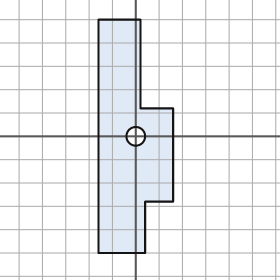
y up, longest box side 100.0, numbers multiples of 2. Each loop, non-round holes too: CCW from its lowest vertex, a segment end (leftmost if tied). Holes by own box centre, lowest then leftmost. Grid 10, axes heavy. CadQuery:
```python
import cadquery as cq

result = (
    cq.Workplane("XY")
    .moveTo(-16.0, -50.0)
    .lineTo(4.0, -50.0)
    .lineTo(4.0, -28.0)
    .lineTo(16.0, -28.0)
    .lineTo(16.0, 12.0)
    .lineTo(2.0, 12.0)
    .lineTo(2.0, 50.0)
    .lineTo(-16.0, 50.0)
    .close()
    .moveTo(0.0, 0.0)
    .circle(4.0)
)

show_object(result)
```